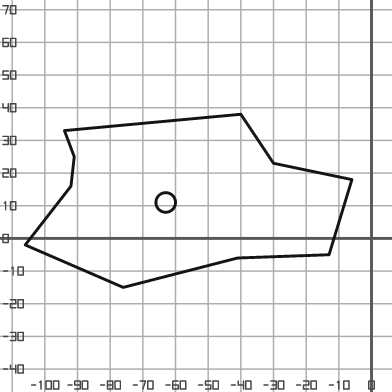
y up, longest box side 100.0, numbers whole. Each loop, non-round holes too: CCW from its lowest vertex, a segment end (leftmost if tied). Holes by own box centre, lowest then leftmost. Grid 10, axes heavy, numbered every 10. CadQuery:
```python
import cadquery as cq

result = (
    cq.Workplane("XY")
    .moveTo(-76.0, -15.0)
    .lineTo(-41.0, -6.0)
    .lineTo(-13.0, -5.0)
    .lineTo(-6.0, 18.0)
    .lineTo(-30.0, 23.0)
    .lineTo(-40.0, 38.0)
    .lineTo(-94.0, 33.0)
    .lineTo(-91.0, 25.0)
    .lineTo(-92.0, 16.0)
    .lineTo(-106.0, -2.0)
    .close()
    .moveTo(-63.0, 11.0)
    .circle(3.0)
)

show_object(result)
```